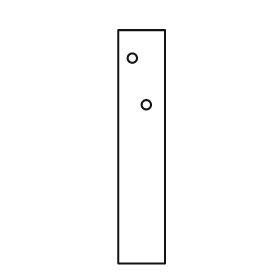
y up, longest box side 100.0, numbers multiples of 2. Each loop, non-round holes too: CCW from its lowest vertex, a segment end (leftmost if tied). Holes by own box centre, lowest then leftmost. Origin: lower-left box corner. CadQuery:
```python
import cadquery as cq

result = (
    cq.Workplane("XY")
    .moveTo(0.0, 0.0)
    .lineTo(20.0, 0.0)
    .lineTo(20.0, 100.0)
    .lineTo(0.0, 100.0)
    .close()
    .moveTo(12.0, 68.0)
    .circle(2.0)
    .moveTo(6.0, 88.0)
    .circle(2.0)
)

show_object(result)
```